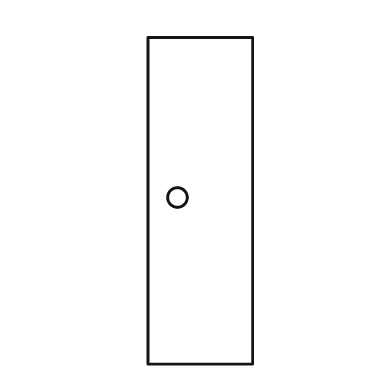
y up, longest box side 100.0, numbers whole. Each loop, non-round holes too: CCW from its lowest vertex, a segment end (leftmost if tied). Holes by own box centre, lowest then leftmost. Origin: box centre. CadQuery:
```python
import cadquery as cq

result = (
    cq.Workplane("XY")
    .moveTo(-16.0, -50.0)
    .lineTo(16.0, -50.0)
    .lineTo(16.0, 50.0)
    .lineTo(-16.0, 50.0)
    .close()
    .moveTo(-7.0, 1.0)
    .circle(3.0)
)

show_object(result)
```